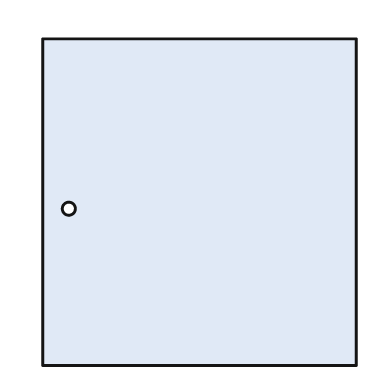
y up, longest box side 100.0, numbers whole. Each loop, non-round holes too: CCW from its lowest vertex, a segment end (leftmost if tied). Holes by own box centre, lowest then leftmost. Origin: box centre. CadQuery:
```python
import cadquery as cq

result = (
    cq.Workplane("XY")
    .moveTo(-48.0, -50.0)
    .lineTo(48.0, -50.0)
    .lineTo(48.0, 50.0)
    .lineTo(-48.0, 50.0)
    .close()
    .moveTo(-40.0, -2.0)
    .circle(2.0)
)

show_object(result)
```